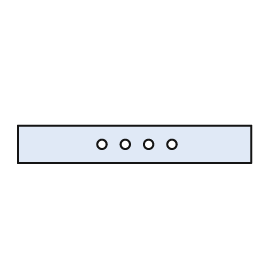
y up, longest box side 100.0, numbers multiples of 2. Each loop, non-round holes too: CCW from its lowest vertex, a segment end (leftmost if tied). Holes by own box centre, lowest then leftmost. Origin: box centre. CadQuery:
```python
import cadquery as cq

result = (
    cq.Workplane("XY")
    .moveTo(-50.0, -8.0)
    .lineTo(50.0, -8.0)
    .lineTo(50.0, 8.0)
    .lineTo(-50.0, 8.0)
    .close()
    .moveTo(-14.0, 0.0)
    .circle(2.0)
    .moveTo(-4.0, 0.0)
    .circle(2.0)
    .moveTo(6.0, 0.0)
    .circle(2.0)
    .moveTo(16.0, 0.0)
    .circle(2.0)
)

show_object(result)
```